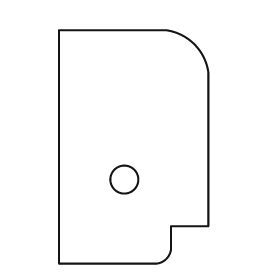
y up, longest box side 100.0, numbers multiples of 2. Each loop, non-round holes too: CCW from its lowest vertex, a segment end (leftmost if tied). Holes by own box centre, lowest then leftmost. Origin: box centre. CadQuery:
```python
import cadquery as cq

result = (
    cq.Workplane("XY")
    .moveTo(-32.0, -50.0)
    .lineTo(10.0, -50.0)
    .threePointArc((14.0, -48.0), (16.0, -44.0))
    .lineTo(16.0, -34.0)
    .lineTo(32.0, -34.0)
    .lineTo(32.0, 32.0)
    .threePointArc((26.0, 44.0), (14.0, 50.0))
    .lineTo(-32.0, 50.0)
    .close()
    .moveTo(-4.0, -14.0)
    .circle(6.0)
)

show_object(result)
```